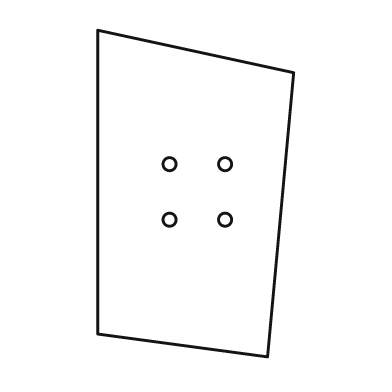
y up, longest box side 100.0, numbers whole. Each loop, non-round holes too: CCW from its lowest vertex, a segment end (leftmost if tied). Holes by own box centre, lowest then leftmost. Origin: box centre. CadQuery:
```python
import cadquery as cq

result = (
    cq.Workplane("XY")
    .moveTo(22.0, -50.0)
    .lineTo(30.0, 37.0)
    .lineTo(-30.0, 50.0)
    .lineTo(-30.0, -43.0)
    .close()
    .moveTo(-8.0, -8.0)
    .circle(2.0)
    .moveTo(9.0, -8.0)
    .circle(2.0)
    .moveTo(-8.0, 9.0)
    .circle(2.0)
    .moveTo(9.0, 9.0)
    .circle(2.0)
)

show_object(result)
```